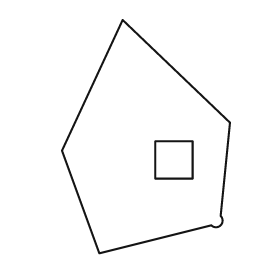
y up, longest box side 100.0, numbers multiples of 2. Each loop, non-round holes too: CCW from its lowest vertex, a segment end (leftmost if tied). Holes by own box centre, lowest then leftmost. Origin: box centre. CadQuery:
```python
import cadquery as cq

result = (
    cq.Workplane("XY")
    .moveTo(-20.0, -50.0)
    .lineTo(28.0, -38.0)
    .threePointArc((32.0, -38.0), (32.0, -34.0))
    .lineTo(36.0, 6.0)
    .lineTo(-10.0, 50.0)
    .lineTo(-36.0, -6.0)
    .close()
    .moveTo(4.0, -18.0)
    .lineTo(20.0, -18.0)
    .lineTo(20.0, -2.0)
    .lineTo(4.0, -2.0)
    .close()
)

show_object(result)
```